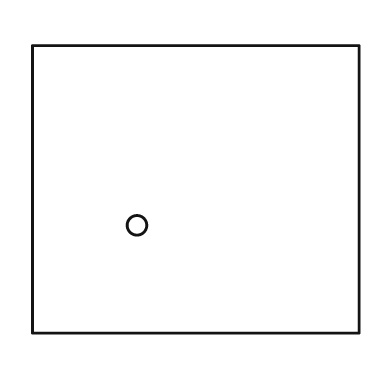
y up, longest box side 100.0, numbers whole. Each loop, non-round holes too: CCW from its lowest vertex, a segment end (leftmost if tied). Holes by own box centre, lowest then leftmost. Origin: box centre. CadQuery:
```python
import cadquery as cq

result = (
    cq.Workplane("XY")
    .moveTo(-50.0, -44.0)
    .lineTo(50.0, -44.0)
    .lineTo(50.0, 44.0)
    .lineTo(-50.0, 44.0)
    .close()
    .moveTo(-18.0, -11.0)
    .circle(3.0)
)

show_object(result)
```